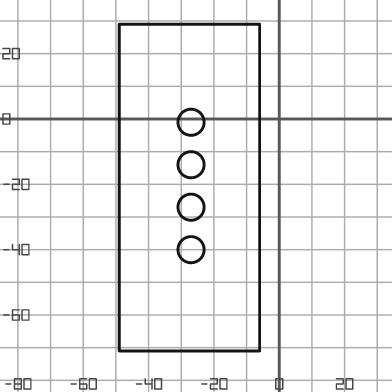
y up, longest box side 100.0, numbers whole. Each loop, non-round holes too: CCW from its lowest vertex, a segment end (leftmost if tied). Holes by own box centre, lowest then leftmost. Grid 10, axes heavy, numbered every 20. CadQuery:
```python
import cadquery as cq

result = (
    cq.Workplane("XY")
    .moveTo(-49.0, -71.0)
    .lineTo(-6.0, -71.0)
    .lineTo(-6.0, 29.0)
    .lineTo(-49.0, 29.0)
    .close()
    .moveTo(-27.0, -40.0)
    .circle(4.0)
    .moveTo(-27.0, -27.0)
    .circle(4.0)
    .moveTo(-27.0, -14.0)
    .circle(4.0)
    .moveTo(-27.0, -1.0)
    .circle(4.0)
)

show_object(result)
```